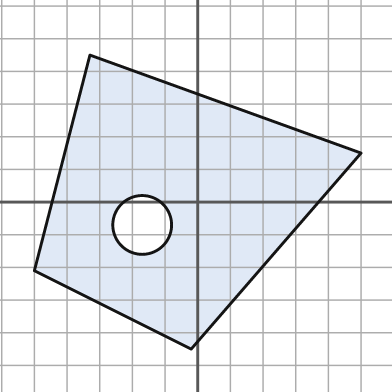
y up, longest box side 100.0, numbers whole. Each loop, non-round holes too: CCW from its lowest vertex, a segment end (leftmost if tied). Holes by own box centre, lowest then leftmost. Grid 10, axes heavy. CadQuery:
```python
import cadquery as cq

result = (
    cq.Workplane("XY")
    .moveTo(-2.0, -45.0)
    .lineTo(50.0, 15.0)
    .lineTo(-33.0, 45.0)
    .lineTo(-50.0, -21.0)
    .close()
    .moveTo(-17.0, -7.0)
    .circle(9.0)
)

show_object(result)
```